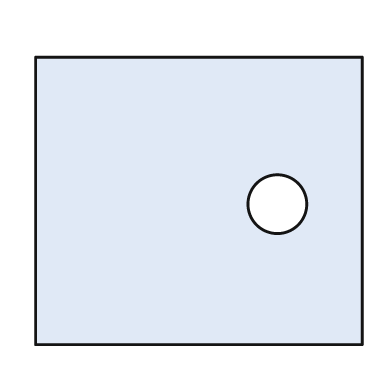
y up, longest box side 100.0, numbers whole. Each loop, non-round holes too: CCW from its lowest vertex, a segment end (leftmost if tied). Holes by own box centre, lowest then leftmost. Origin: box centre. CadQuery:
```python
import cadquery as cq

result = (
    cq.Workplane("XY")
    .moveTo(-50.0, -44.0)
    .lineTo(50.0, -44.0)
    .lineTo(50.0, 44.0)
    .lineTo(-50.0, 44.0)
    .close()
    .moveTo(24.0, -1.0)
    .circle(9.0)
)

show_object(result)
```